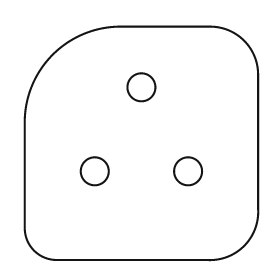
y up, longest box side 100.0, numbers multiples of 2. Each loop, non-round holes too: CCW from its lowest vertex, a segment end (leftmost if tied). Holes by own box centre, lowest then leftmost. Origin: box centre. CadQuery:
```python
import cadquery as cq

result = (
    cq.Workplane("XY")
    .moveTo(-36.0, -50.0)
    .lineTo(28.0, -50.0)
    .threePointArc((44.0, -44.0), (50.0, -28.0))
    .lineTo(50.0, 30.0)
    .threePointArc((44.0, 44.0), (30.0, 50.0))
    .lineTo(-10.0, 50.0)
    .threePointArc((-38.0, 38.0), (-50.0, 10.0))
    .lineTo(-50.0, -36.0)
    .threePointArc((-46.0, -46.0), (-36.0, -50.0))
    .close()
    .moveTo(-20.0, -12.0)
    .circle(6.0)
    .moveTo(20.0, -12.0)
    .circle(6.0)
    .moveTo(0.0, 24.0)
    .circle(6.0)
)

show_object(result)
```